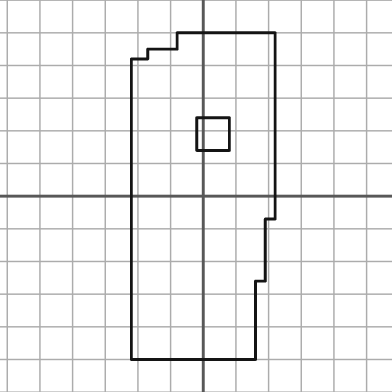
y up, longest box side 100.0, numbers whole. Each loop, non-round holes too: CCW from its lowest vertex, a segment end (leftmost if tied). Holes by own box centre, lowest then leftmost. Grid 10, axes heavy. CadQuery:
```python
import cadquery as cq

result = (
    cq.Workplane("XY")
    .moveTo(-22.0, -50.0)
    .lineTo(16.0, -50.0)
    .lineTo(16.0, -26.0)
    .lineTo(19.0, -26.0)
    .lineTo(19.0, -7.0)
    .lineTo(22.0, -7.0)
    .lineTo(22.0, 50.0)
    .lineTo(-8.0, 50.0)
    .lineTo(-8.0, 45.0)
    .lineTo(-17.0, 45.0)
    .lineTo(-17.0, 42.0)
    .lineTo(-22.0, 42.0)
    .close()
    .moveTo(-2.0, 14.0)
    .lineTo(8.0, 14.0)
    .lineTo(8.0, 24.0)
    .lineTo(-2.0, 24.0)
    .close()
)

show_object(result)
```